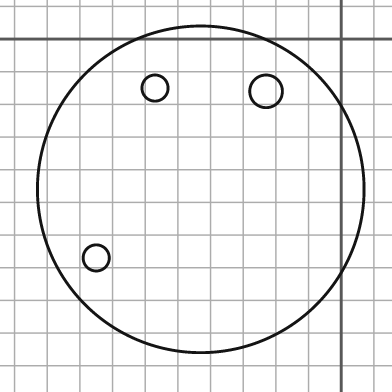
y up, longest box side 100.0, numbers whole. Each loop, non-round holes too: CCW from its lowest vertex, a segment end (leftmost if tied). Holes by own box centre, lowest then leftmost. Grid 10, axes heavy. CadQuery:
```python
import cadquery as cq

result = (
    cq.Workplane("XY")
    .moveTo(-43.0, -46.0)
    .circle(50.0)
    .moveTo(-75.0, -67.0)
    .circle(4.0)
    .moveTo(-23.0, -16.0)
    .circle(5.0)
    .moveTo(-57.0, -15.0)
    .circle(4.0)
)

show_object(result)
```